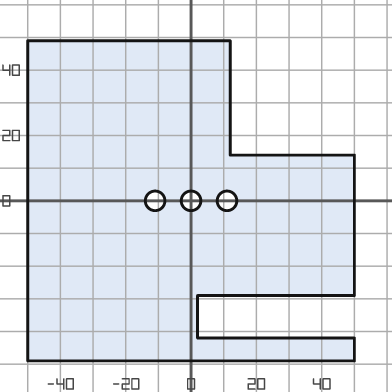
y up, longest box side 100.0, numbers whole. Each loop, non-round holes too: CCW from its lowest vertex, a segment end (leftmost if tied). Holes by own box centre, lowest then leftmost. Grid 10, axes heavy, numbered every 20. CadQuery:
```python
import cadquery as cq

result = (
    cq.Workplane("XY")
    .moveTo(-50.0, -49.0)
    .lineTo(50.0, -49.0)
    .lineTo(50.0, -42.0)
    .lineTo(2.0, -42.0)
    .lineTo(2.0, -29.0)
    .lineTo(50.0, -29.0)
    .lineTo(50.0, 14.0)
    .lineTo(12.0, 14.0)
    .lineTo(12.0, 49.0)
    .lineTo(-50.0, 49.0)
    .close()
    .moveTo(-11.0, 0.0)
    .circle(3.0)
    .moveTo(0.0, 0.0)
    .circle(3.0)
    .moveTo(11.0, 0.0)
    .circle(3.0)
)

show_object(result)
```